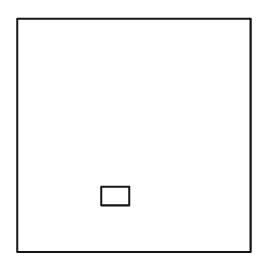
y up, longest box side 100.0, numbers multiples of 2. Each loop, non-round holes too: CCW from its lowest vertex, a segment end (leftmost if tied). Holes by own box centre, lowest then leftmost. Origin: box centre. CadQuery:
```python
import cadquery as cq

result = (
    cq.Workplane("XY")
    .moveTo(-50.0, -50.0)
    .lineTo(50.0, -50.0)
    .lineTo(50.0, 50.0)
    .lineTo(-50.0, 50.0)
    .close()
    .moveTo(-14.0, -30.0)
    .lineTo(-2.0, -30.0)
    .lineTo(-2.0, -22.0)
    .lineTo(-14.0, -22.0)
    .close()
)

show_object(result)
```